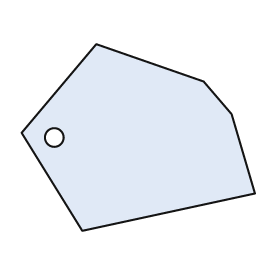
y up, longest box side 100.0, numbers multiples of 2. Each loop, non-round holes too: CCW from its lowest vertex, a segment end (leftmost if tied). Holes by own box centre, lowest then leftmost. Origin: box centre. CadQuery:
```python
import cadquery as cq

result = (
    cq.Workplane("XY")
    .moveTo(-24.0, -40.0)
    .lineTo(50.0, -24.0)
    .lineTo(40.0, 10.0)
    .lineTo(28.0, 24.0)
    .lineTo(-18.0, 40.0)
    .lineTo(-50.0, 2.0)
    .close()
    .moveTo(-36.0, 0.0)
    .circle(4.0)
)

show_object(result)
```